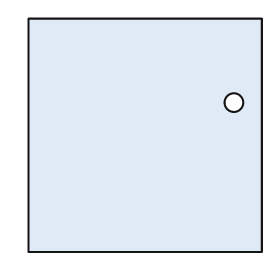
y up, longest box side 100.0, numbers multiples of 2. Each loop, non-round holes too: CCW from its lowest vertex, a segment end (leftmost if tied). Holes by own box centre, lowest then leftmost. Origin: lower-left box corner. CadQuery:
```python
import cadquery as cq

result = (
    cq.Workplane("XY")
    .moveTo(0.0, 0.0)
    .lineTo(100.0, 0.0)
    .lineTo(100.0, 100.0)
    .lineTo(0.0, 100.0)
    .close()
    .moveTo(88.0, 64.0)
    .circle(4.0)
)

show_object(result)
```